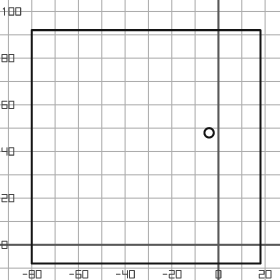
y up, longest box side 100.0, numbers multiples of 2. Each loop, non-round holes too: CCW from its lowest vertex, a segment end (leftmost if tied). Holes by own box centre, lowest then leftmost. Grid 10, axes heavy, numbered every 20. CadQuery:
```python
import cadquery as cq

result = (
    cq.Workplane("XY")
    .moveTo(-80.0, -8.0)
    .lineTo(18.0, -8.0)
    .lineTo(18.0, 92.0)
    .lineTo(-80.0, 92.0)
    .close()
    .moveTo(-4.0, 48.0)
    .circle(2.0)
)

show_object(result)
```